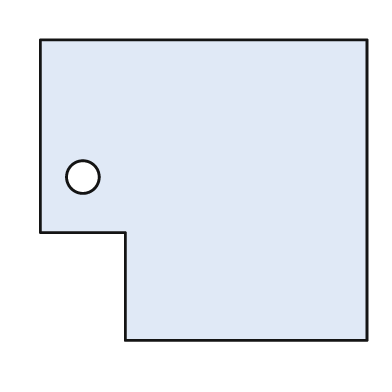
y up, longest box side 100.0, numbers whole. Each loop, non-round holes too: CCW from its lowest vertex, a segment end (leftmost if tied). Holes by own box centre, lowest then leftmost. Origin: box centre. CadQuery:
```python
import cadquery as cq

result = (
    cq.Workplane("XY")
    .moveTo(-24.0, -46.0)
    .lineTo(50.0, -46.0)
    .lineTo(50.0, 46.0)
    .lineTo(-50.0, 46.0)
    .lineTo(-50.0, -13.0)
    .lineTo(-24.0, -13.0)
    .close()
    .moveTo(-37.0, 4.0)
    .circle(5.0)
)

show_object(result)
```